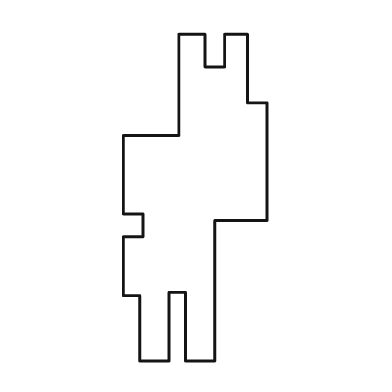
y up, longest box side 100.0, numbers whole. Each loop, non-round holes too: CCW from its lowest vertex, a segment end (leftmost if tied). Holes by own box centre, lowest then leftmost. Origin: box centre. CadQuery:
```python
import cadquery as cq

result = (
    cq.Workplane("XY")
    .moveTo(-17.0, -50.0)
    .lineTo(-8.0, -50.0)
    .lineTo(-8.0, -29.0)
    .lineTo(-3.0, -29.0)
    .lineTo(-3.0, -50.0)
    .lineTo(6.0, -50.0)
    .lineTo(6.0, -7.0)
    .lineTo(22.0, -7.0)
    .lineTo(22.0, 29.0)
    .lineTo(16.0, 29.0)
    .lineTo(16.0, 50.0)
    .lineTo(9.0, 50.0)
    .lineTo(9.0, 40.0)
    .lineTo(3.0, 40.0)
    .lineTo(3.0, 50.0)
    .lineTo(-5.0, 50.0)
    .lineTo(-5.0, 19.0)
    .lineTo(-22.0, 19.0)
    .lineTo(-22.0, -5.0)
    .lineTo(-16.0, -5.0)
    .lineTo(-16.0, -12.0)
    .lineTo(-22.0, -12.0)
    .lineTo(-22.0, -30.0)
    .lineTo(-17.0, -30.0)
    .close()
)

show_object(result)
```